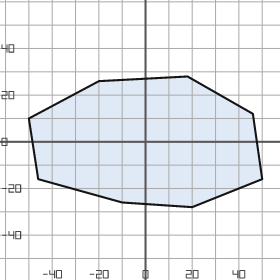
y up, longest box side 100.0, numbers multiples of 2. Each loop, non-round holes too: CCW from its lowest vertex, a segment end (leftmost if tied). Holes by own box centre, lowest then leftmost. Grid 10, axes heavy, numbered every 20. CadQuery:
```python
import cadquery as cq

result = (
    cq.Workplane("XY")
    .moveTo(20.0, -28.0)
    .lineTo(50.0, -16.0)
    .lineTo(46.0, 12.0)
    .lineTo(18.0, 28.0)
    .lineTo(-20.0, 26.0)
    .lineTo(-50.0, 10.0)
    .lineTo(-46.0, -16.0)
    .lineTo(-10.0, -26.0)
    .close()
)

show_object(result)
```